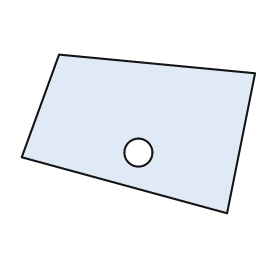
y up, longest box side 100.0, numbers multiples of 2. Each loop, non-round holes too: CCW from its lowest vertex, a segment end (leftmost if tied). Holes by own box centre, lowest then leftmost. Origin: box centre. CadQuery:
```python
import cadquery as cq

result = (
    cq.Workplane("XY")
    .moveTo(38.0, -34.0)
    .lineTo(50.0, 26.0)
    .lineTo(-34.0, 34.0)
    .lineTo(-50.0, -10.0)
    .close()
    .moveTo(0.0, -8.0)
    .circle(6.0)
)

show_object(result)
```